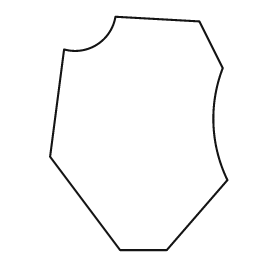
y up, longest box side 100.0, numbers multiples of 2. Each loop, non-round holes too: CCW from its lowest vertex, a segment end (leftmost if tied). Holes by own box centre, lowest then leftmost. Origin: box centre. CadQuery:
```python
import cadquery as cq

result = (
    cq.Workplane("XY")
    .moveTo(-8.0, -50.0)
    .lineTo(12.0, -50.0)
    .lineTo(38.0, -20.0)
    .threePointArc((32.0, 4.0), (36.0, 28.0))
    .lineTo(26.0, 48.0)
    .lineTo(-10.0, 50.0)
    .threePointArc((-18.0, 38.0), (-32.0, 36.0))
    .lineTo(-38.0, -10.0)
    .close()
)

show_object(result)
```